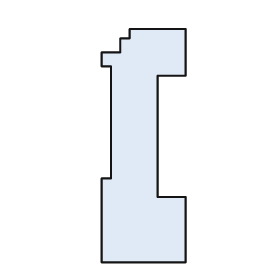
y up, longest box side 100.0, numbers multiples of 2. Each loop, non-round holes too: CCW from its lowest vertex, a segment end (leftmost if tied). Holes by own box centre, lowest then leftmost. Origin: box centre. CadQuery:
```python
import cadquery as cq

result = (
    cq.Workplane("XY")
    .moveTo(-18.0, -50.0)
    .lineTo(18.0, -50.0)
    .lineTo(18.0, -22.0)
    .lineTo(6.0, -22.0)
    .lineTo(6.0, 30.0)
    .lineTo(18.0, 30.0)
    .lineTo(18.0, 50.0)
    .lineTo(-6.0, 50.0)
    .lineTo(-6.0, 46.0)
    .lineTo(-10.0, 46.0)
    .lineTo(-10.0, 40.0)
    .lineTo(-18.0, 40.0)
    .lineTo(-18.0, 34.0)
    .lineTo(-14.0, 34.0)
    .lineTo(-14.0, -14.0)
    .lineTo(-18.0, -14.0)
    .close()
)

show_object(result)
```